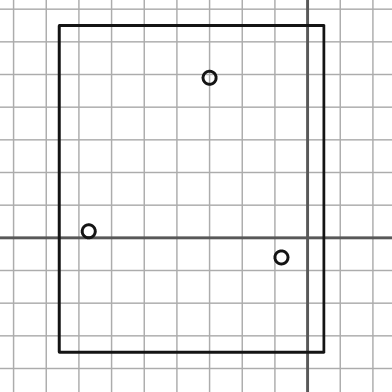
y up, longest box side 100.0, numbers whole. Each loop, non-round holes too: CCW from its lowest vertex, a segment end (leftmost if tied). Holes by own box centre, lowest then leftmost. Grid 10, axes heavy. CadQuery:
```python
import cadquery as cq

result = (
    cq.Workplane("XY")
    .moveTo(-76.0, -35.0)
    .lineTo(5.0, -35.0)
    .lineTo(5.0, 65.0)
    .lineTo(-76.0, 65.0)
    .close()
    .moveTo(-8.0, -6.0)
    .circle(2.0)
    .moveTo(-67.0, 2.0)
    .circle(2.0)
    .moveTo(-30.0, 49.0)
    .circle(2.0)
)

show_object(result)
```